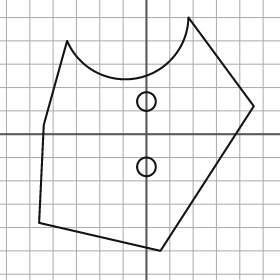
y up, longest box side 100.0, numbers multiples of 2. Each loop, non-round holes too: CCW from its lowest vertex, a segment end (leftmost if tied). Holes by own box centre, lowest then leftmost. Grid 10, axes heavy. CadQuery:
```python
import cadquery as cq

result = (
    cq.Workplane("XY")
    .moveTo(6.0, -50.0)
    .lineTo(46.0, 12.0)
    .lineTo(18.0, 50.0)
    .threePointArc((-4.0, 24.0), (-34.0, 40.0))
    .lineTo(-44.0, 4.0)
    .lineTo(-46.0, -38.0)
    .close()
    .moveTo(0.0, -14.0)
    .circle(4.0)
    .moveTo(0.0, 14.0)
    .circle(4.0)
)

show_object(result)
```